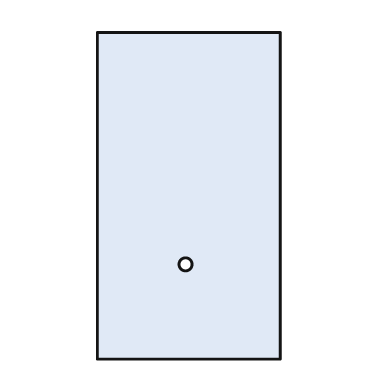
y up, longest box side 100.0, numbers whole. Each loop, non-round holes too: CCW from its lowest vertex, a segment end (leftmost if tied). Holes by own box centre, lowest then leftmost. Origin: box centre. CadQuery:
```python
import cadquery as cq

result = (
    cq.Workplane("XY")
    .moveTo(-28.0, -50.0)
    .lineTo(28.0, -50.0)
    .lineTo(28.0, 50.0)
    .lineTo(-28.0, 50.0)
    .close()
    .moveTo(-1.0, -21.0)
    .circle(2.0)
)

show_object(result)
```